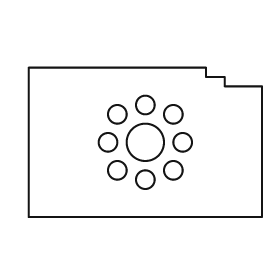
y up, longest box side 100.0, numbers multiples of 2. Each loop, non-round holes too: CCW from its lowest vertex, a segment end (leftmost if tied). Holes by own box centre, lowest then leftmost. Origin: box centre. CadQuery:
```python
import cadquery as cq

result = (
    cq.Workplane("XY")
    .moveTo(-50.0, -32.0)
    .lineTo(50.0, -32.0)
    .lineTo(50.0, 24.0)
    .lineTo(34.0, 24.0)
    .lineTo(34.0, 28.0)
    .lineTo(26.0, 28.0)
    .lineTo(26.0, 32.0)
    .lineTo(-50.0, 32.0)
    .close()
    .moveTo(0.0, -16.0)
    .circle(4.0)
    .moveTo(-12.0, -12.0)
    .circle(4.0)
    .moveTo(12.0, -12.0)
    .circle(4.0)
    .moveTo(-16.0, 0.0)
    .circle(4.0)
    .moveTo(0.0, 0.0)
    .circle(8.0)
    .moveTo(16.0, 0.0)
    .circle(4.0)
    .moveTo(-12.0, 12.0)
    .circle(4.0)
    .moveTo(12.0, 12.0)
    .circle(4.0)
    .moveTo(0.0, 16.0)
    .circle(4.0)
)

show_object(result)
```